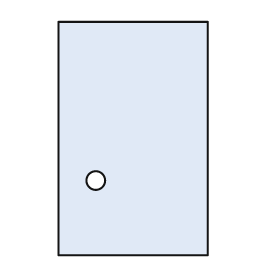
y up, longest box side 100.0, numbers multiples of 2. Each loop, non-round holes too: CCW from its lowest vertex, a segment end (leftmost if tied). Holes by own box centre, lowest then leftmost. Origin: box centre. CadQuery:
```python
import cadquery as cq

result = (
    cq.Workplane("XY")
    .moveTo(-32.0, -50.0)
    .lineTo(32.0, -50.0)
    .lineTo(32.0, 50.0)
    .lineTo(-32.0, 50.0)
    .close()
    .moveTo(-16.0, -18.0)
    .circle(4.0)
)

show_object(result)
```